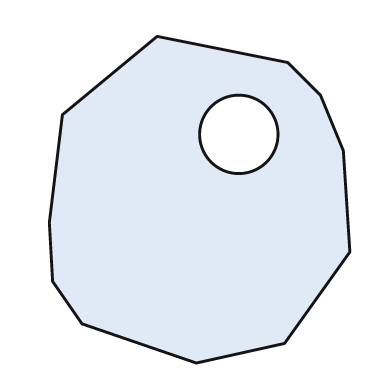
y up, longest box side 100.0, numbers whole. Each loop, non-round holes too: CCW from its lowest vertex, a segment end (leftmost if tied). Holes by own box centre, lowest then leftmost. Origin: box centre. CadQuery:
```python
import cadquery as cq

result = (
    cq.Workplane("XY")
    .moveTo(-1.0, -50.0)
    .lineTo(26.0, -44.0)
    .lineTo(46.0, -16.0)
    .lineTo(44.0, 15.0)
    .lineTo(37.0, 32.0)
    .lineTo(27.0, 42.0)
    .lineTo(-13.0, 50.0)
    .lineTo(-42.0, 26.0)
    .lineTo(-46.0, -7.0)
    .lineTo(-45.0, -25.0)
    .lineTo(-36.0, -38.0)
    .close()
    .moveTo(12.0, 20.0)
    .circle(12.0)
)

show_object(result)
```